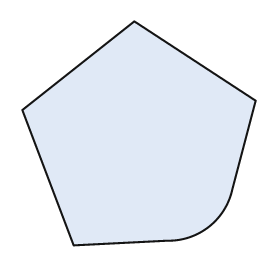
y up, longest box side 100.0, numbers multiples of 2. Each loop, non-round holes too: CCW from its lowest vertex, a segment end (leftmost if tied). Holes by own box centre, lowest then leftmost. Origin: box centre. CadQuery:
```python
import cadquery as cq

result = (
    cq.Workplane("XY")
    .moveTo(-28.0, -48.0)
    .lineTo(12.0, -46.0)
    .threePointArc((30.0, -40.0), (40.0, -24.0))
    .lineTo(50.0, 14.0)
    .lineTo(-2.0, 48.0)
    .lineTo(-50.0, 10.0)
    .close()
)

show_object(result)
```